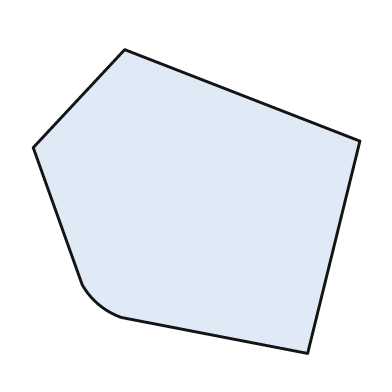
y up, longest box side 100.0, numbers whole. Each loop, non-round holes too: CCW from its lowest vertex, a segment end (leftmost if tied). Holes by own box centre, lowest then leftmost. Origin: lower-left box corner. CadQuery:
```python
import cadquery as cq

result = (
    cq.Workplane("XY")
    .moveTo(84.0, 0.0)
    .lineTo(100.0, 65.0)
    .lineTo(28.0, 93.0)
    .lineTo(0.0, 63.0)
    .lineTo(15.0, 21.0)
    .threePointArc((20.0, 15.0), (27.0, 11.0))
    .close()
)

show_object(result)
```